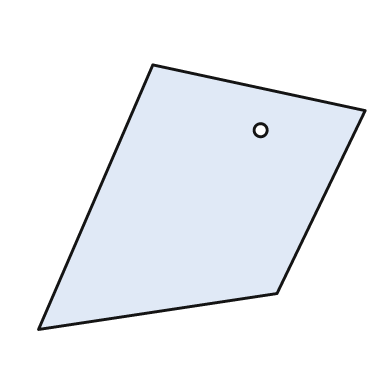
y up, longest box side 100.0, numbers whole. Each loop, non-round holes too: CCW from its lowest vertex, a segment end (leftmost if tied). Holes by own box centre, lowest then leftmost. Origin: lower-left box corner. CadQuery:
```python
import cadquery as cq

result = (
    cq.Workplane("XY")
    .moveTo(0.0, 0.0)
    .lineTo(73.0, 11.0)
    .lineTo(100.0, 67.0)
    .lineTo(35.0, 81.0)
    .close()
    .moveTo(68.0, 61.0)
    .circle(2.0)
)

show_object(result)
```